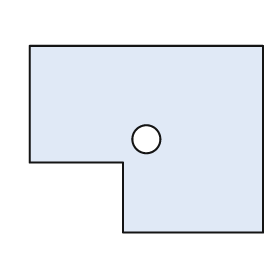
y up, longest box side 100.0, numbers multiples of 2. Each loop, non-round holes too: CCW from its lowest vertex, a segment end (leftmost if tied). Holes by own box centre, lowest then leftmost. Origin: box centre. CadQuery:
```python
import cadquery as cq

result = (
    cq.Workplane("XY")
    .moveTo(-10.0, -40.0)
    .lineTo(50.0, -40.0)
    .lineTo(50.0, 40.0)
    .lineTo(-50.0, 40.0)
    .lineTo(-50.0, -10.0)
    .lineTo(-10.0, -10.0)
    .close()
    .moveTo(0.0, 0.0)
    .circle(6.0)
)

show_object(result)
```